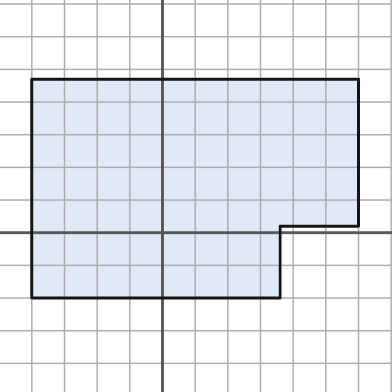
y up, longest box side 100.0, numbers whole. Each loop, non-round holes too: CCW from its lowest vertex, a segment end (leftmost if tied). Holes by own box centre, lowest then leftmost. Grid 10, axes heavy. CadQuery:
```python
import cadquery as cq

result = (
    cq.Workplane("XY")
    .moveTo(-40.0, -20.0)
    .lineTo(36.0, -20.0)
    .lineTo(36.0, 2.0)
    .lineTo(60.0, 2.0)
    .lineTo(60.0, 47.0)
    .lineTo(-40.0, 47.0)
    .close()
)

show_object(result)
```